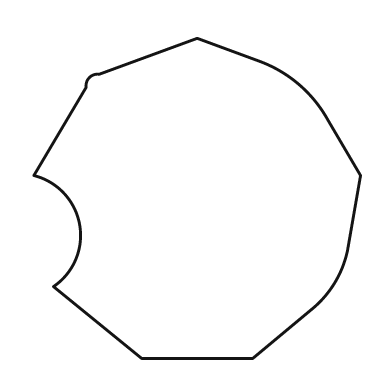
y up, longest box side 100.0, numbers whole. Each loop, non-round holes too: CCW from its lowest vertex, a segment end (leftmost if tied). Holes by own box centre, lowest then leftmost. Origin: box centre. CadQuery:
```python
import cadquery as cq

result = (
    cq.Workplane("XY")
    .moveTo(-17.0, -49.0)
    .lineTo(17.0, -49.0)
    .lineTo(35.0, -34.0)
    .threePointArc((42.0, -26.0), (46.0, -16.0))
    .lineTo(50.0, 7.0)
    .lineTo(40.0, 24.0)
    .threePointArc((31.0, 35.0), (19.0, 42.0))
    .lineTo(0.0, 49.0)
    .lineTo(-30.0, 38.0)
    .threePointArc((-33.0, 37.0), (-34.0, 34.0))
    .lineTo(-50.0, 7.0)
    .threePointArc((-36.0, -8.0), (-44.0, -27.0))
    .close()
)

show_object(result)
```